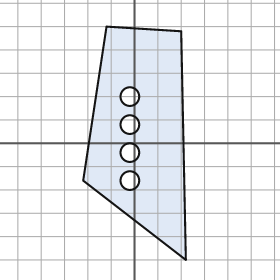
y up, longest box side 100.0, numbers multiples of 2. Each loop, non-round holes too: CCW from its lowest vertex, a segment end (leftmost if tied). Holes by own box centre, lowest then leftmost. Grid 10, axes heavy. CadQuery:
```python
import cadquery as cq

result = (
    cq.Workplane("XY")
    .moveTo(22.0, -50.0)
    .lineTo(20.0, 48.0)
    .lineTo(-12.0, 50.0)
    .lineTo(-22.0, -16.0)
    .close()
    .moveTo(-2.0, -16.0)
    .circle(4.0)
    .moveTo(-2.0, -4.0)
    .circle(4.0)
    .moveTo(-2.0, 8.0)
    .circle(4.0)
    .moveTo(-2.0, 20.0)
    .circle(4.0)
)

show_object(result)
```